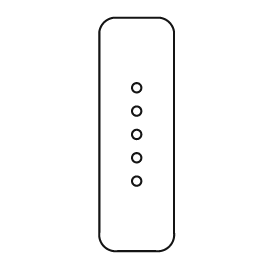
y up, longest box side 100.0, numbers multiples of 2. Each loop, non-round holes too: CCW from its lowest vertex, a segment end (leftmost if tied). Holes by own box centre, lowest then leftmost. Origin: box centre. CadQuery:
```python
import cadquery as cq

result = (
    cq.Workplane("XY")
    .moveTo(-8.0, -50.0)
    .lineTo(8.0, -50.0)
    .threePointArc((14.0, -48.0), (16.0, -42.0))
    .lineTo(16.0, 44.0)
    .threePointArc((14.0, 48.0), (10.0, 50.0))
    .lineTo(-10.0, 50.0)
    .threePointArc((-14.0, 48.0), (-16.0, 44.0))
    .lineTo(-16.0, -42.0)
    .threePointArc((-14.0, -48.0), (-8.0, -50.0))
    .close()
    .moveTo(0.0, -20.0)
    .circle(2.0)
    .moveTo(0.0, -10.0)
    .circle(2.0)
    .moveTo(0.0, 0.0)
    .circle(2.0)
    .moveTo(0.0, 10.0)
    .circle(2.0)
    .moveTo(0.0, 20.0)
    .circle(2.0)
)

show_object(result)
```